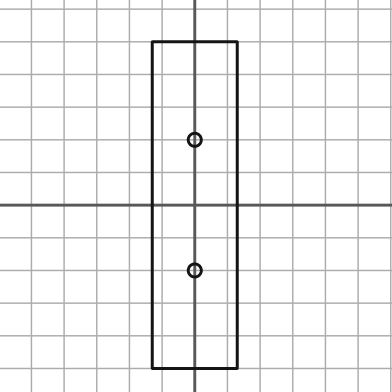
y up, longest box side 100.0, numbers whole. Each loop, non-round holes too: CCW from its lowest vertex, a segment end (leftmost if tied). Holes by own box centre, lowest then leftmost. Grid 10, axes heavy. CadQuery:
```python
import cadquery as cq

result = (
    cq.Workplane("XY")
    .moveTo(-13.0, -50.0)
    .lineTo(13.0, -50.0)
    .lineTo(13.0, 50.0)
    .lineTo(-13.0, 50.0)
    .close()
    .moveTo(0.0, -20.0)
    .circle(2.0)
    .moveTo(0.0, 20.0)
    .circle(2.0)
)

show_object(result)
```